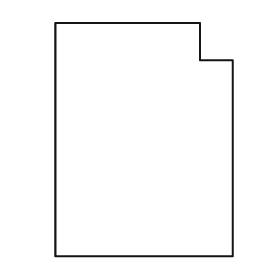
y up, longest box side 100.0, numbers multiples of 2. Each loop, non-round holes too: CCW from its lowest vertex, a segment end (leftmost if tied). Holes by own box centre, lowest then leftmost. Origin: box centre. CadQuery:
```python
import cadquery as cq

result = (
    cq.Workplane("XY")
    .moveTo(-38.0, -50.0)
    .lineTo(38.0, -50.0)
    .lineTo(38.0, 34.0)
    .lineTo(24.0, 34.0)
    .lineTo(24.0, 50.0)
    .lineTo(-38.0, 50.0)
    .close()
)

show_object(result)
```